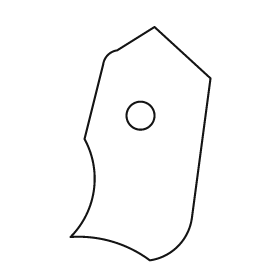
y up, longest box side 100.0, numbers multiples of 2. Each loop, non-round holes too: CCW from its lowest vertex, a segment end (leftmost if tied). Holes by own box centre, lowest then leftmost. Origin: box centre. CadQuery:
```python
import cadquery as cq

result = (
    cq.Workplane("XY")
    .moveTo(4.0, -50.0)
    .threePointArc((16.0, -44.0), (22.0, -32.0))
    .lineTo(30.0, 28.0)
    .lineTo(6.0, 50.0)
    .lineTo(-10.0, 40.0)
    .threePointArc((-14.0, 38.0), (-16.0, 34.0))
    .lineTo(-24.0, 2.0)
    .threePointArc((-20.0, -20.0), (-30.0, -40.0))
    .threePointArc((-12.0, -42.0), (4.0, -50.0))
    .close()
    .moveTo(0.0, 12.0)
    .circle(6.0)
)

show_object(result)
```